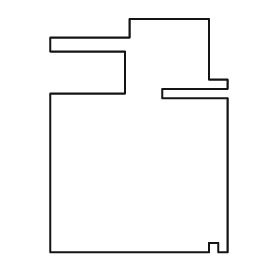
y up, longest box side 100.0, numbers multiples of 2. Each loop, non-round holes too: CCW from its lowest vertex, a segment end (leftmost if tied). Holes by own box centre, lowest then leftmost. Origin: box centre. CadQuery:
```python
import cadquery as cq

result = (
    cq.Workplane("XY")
    .moveTo(-38.0, -50.0)
    .lineTo(30.0, -50.0)
    .lineTo(30.0, -46.0)
    .lineTo(34.0, -46.0)
    .lineTo(34.0, -50.0)
    .lineTo(38.0, -50.0)
    .lineTo(38.0, 16.0)
    .lineTo(10.0, 16.0)
    .lineTo(10.0, 20.0)
    .lineTo(38.0, 20.0)
    .lineTo(38.0, 24.0)
    .lineTo(30.0, 24.0)
    .lineTo(30.0, 50.0)
    .lineTo(-4.0, 50.0)
    .lineTo(-4.0, 42.0)
    .lineTo(-38.0, 42.0)
    .lineTo(-38.0, 36.0)
    .lineTo(-6.0, 36.0)
    .lineTo(-6.0, 18.0)
    .lineTo(-38.0, 18.0)
    .close()
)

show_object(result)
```